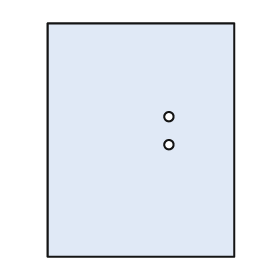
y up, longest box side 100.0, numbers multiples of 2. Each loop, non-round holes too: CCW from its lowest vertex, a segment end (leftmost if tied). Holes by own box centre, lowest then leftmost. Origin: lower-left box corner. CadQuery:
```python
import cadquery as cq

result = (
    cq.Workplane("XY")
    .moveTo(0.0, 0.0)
    .lineTo(80.0, 0.0)
    .lineTo(80.0, 100.0)
    .lineTo(0.0, 100.0)
    .close()
    .moveTo(52.0, 48.0)
    .circle(2.0)
    .moveTo(52.0, 60.0)
    .circle(2.0)
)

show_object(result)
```